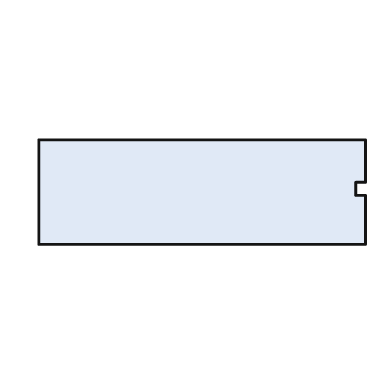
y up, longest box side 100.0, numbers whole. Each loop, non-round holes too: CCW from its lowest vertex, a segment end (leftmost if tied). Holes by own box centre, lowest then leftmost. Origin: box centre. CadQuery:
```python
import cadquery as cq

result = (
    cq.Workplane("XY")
    .moveTo(-50.0, -16.0)
    .lineTo(50.0, -16.0)
    .lineTo(50.0, -1.0)
    .lineTo(47.0, -1.0)
    .lineTo(47.0, 3.0)
    .lineTo(50.0, 3.0)
    .lineTo(50.0, 16.0)
    .lineTo(-50.0, 16.0)
    .close()
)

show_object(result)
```